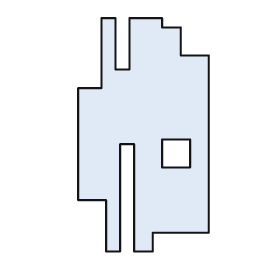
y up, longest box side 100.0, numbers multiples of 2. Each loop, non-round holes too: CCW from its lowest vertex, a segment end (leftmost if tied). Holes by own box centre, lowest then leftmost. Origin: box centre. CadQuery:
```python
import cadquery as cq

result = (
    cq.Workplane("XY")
    .moveTo(-16.0, -50.0)
    .lineTo(-10.0, -50.0)
    .lineTo(-10.0, -4.0)
    .lineTo(-4.0, -4.0)
    .lineTo(-4.0, -50.0)
    .lineTo(4.0, -50.0)
    .lineTo(4.0, -42.0)
    .lineTo(28.0, -42.0)
    .lineTo(28.0, 34.0)
    .lineTo(16.0, 34.0)
    .lineTo(16.0, 46.0)
    .lineTo(8.0, 46.0)
    .lineTo(8.0, 50.0)
    .lineTo(-6.0, 50.0)
    .lineTo(-6.0, 28.0)
    .lineTo(-12.0, 28.0)
    .lineTo(-12.0, 50.0)
    .lineTo(-18.0, 50.0)
    .lineTo(-18.0, 20.0)
    .lineTo(-28.0, 20.0)
    .lineTo(-28.0, -28.0)
    .lineTo(-16.0, -28.0)
    .close()
    .moveTo(8.0, -14.0)
    .lineTo(20.0, -14.0)
    .lineTo(20.0, -2.0)
    .lineTo(8.0, -2.0)
    .close()
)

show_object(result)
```